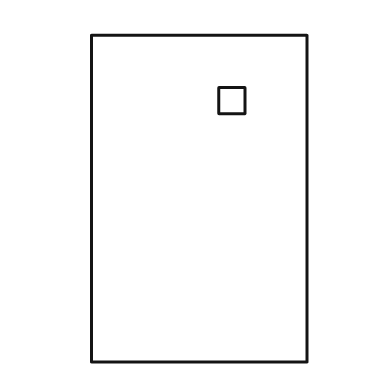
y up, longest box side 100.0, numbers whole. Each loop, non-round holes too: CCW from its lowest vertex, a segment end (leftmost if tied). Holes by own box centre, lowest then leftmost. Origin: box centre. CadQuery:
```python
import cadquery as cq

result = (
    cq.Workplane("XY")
    .moveTo(-33.0, -50.0)
    .lineTo(33.0, -50.0)
    .lineTo(33.0, 50.0)
    .lineTo(-33.0, 50.0)
    .close()
    .moveTo(6.0, 26.0)
    .lineTo(14.0, 26.0)
    .lineTo(14.0, 34.0)
    .lineTo(6.0, 34.0)
    .close()
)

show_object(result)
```